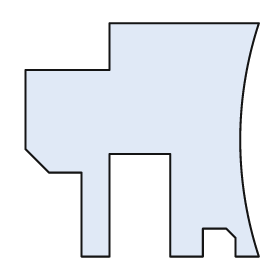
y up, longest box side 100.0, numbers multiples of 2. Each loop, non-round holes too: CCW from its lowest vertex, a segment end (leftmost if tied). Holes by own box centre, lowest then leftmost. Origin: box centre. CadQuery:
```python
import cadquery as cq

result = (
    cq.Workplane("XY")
    .moveTo(-26.0, -50.0)
    .lineTo(-14.0, -50.0)
    .lineTo(-14.0, -6.0)
    .lineTo(12.0, -6.0)
    .lineTo(12.0, -50.0)
    .lineTo(26.0, -50.0)
    .lineTo(26.0, -38.0)
    .lineTo(36.0, -38.0)
    .lineTo(40.0, -42.0)
    .lineTo(40.0, -50.0)
    .lineTo(50.0, -50.0)
    .threePointArc((42.0, 0.0), (50.0, 50.0))
    .lineTo(-14.0, 50.0)
    .lineTo(-14.0, 30.0)
    .lineTo(-50.0, 30.0)
    .lineTo(-50.0, -4.0)
    .lineTo(-40.0, -14.0)
    .lineTo(-26.0, -14.0)
    .close()
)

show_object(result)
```